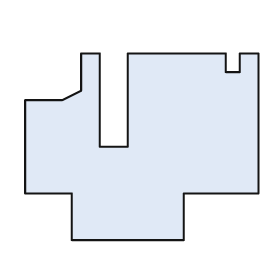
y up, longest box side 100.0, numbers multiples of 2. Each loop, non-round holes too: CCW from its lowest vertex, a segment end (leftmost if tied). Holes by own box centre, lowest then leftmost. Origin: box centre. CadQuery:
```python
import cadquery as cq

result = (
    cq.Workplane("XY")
    .moveTo(-30.0, -40.0)
    .lineTo(18.0, -40.0)
    .lineTo(18.0, -20.0)
    .lineTo(50.0, -20.0)
    .lineTo(50.0, 40.0)
    .lineTo(42.0, 40.0)
    .lineTo(42.0, 32.0)
    .lineTo(36.0, 32.0)
    .lineTo(36.0, 40.0)
    .lineTo(-6.0, 40.0)
    .lineTo(-6.0, 0.0)
    .lineTo(-18.0, 0.0)
    .lineTo(-18.0, 40.0)
    .lineTo(-26.0, 40.0)
    .lineTo(-26.0, 24.0)
    .lineTo(-34.0, 20.0)
    .lineTo(-50.0, 20.0)
    .lineTo(-50.0, -20.0)
    .lineTo(-30.0, -20.0)
    .close()
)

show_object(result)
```